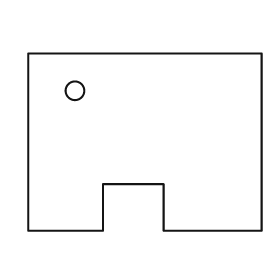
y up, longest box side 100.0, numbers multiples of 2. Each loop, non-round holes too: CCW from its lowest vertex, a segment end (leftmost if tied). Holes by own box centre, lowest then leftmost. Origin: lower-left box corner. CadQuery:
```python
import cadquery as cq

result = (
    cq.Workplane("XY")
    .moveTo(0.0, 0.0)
    .lineTo(32.0, 0.0)
    .lineTo(32.0, 20.0)
    .lineTo(58.0, 20.0)
    .lineTo(58.0, 0.0)
    .lineTo(100.0, 0.0)
    .lineTo(100.0, 76.0)
    .lineTo(0.0, 76.0)
    .close()
    .moveTo(20.0, 60.0)
    .circle(4.0)
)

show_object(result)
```